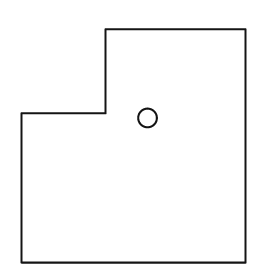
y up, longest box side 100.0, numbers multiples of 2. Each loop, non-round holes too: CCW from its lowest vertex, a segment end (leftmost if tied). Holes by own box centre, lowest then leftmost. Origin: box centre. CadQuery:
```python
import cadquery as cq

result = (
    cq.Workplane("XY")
    .moveTo(-48.0, -50.0)
    .lineTo(48.0, -50.0)
    .lineTo(48.0, 50.0)
    .lineTo(-12.0, 50.0)
    .lineTo(-12.0, 14.0)
    .lineTo(-48.0, 14.0)
    .close()
    .moveTo(6.0, 12.0)
    .circle(4.0)
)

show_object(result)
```